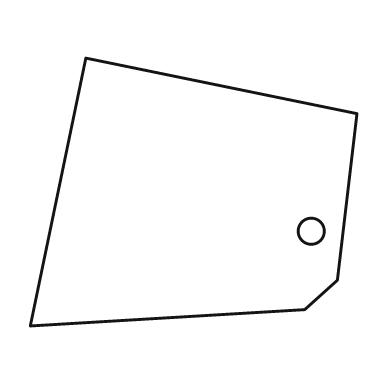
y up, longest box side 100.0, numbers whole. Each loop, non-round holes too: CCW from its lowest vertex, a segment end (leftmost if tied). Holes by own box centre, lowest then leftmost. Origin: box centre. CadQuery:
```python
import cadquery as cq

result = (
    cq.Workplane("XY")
    .moveTo(-50.0, -41.0)
    .lineTo(34.0, -36.0)
    .lineTo(44.0, -27.0)
    .lineTo(50.0, 24.0)
    .lineTo(-33.0, 41.0)
    .close()
    .moveTo(36.0, -12.0)
    .circle(4.0)
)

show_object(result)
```